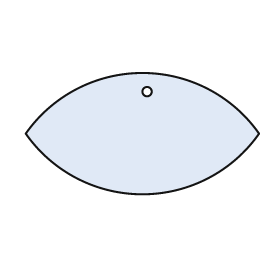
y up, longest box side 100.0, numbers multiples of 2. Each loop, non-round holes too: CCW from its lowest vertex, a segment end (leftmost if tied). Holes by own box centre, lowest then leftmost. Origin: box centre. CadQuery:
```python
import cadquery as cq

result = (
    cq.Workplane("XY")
    .moveTo(-50.0, 0.0)
    .threePointArc((0.0, -26.0), (50.0, 0.0))
    .threePointArc((0.0, 26.0), (-50.0, 0.0))
    .close()
    .moveTo(2.0, 18.0)
    .circle(2.0)
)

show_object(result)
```